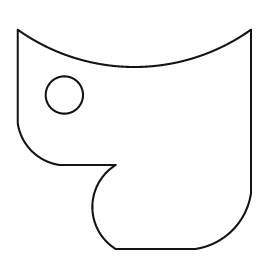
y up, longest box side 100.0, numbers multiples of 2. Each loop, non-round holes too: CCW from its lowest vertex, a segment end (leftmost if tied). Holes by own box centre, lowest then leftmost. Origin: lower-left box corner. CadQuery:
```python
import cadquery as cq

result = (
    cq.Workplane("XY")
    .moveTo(42.0, 0.0)
    .lineTo(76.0, 0.0)
    .threePointArc((92.0, 8.0), (100.0, 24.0))
    .lineTo(100.0, 94.0)
    .threePointArc((50.0, 78.0), (0.0, 94.0))
    .lineTo(0.0, 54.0)
    .threePointArc((6.0, 42.0), (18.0, 36.0))
    .lineTo(42.0, 36.0)
    .threePointArc((32.0, 18.0), (42.0, 0.0))
    .close()
    .moveTo(20.0, 66.0)
    .circle(8.0)
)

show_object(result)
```